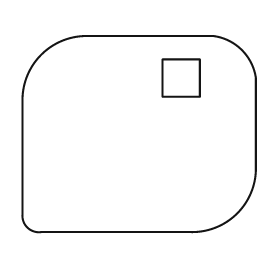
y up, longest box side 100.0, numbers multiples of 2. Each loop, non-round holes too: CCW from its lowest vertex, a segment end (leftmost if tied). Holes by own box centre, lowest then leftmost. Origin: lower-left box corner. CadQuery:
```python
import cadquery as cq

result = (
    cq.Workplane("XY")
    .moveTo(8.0, 0.0)
    .lineTo(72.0, 0.0)
    .threePointArc((92.0, 8.0), (100.0, 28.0))
    .lineTo(100.0, 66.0)
    .threePointArc((94.0, 78.0), (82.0, 84.0))
    .lineTo(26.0, 84.0)
    .threePointArc((8.0, 76.0), (0.0, 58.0))
    .lineTo(0.0, 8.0)
    .threePointArc((2.0, 2.0), (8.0, 0.0))
    .close()
    .moveTo(60.0, 58.0)
    .lineTo(76.0, 58.0)
    .lineTo(76.0, 74.0)
    .lineTo(60.0, 74.0)
    .close()
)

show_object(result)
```